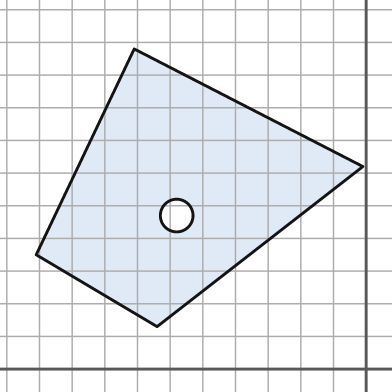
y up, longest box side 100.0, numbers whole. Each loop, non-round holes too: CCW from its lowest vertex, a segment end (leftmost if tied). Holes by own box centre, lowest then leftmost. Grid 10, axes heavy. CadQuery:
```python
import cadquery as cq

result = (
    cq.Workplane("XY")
    .moveTo(-64.0, 13.0)
    .lineTo(-1.0, 62.0)
    .lineTo(-71.0, 98.0)
    .lineTo(-101.0, 35.0)
    .close()
    .moveTo(-58.0, 47.0)
    .circle(5.0)
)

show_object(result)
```